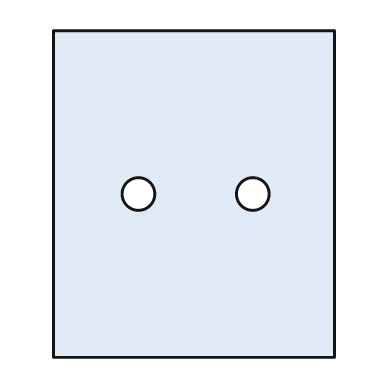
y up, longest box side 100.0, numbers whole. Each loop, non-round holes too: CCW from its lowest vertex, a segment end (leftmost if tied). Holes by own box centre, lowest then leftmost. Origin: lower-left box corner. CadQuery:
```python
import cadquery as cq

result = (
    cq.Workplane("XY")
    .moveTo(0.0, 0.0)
    .lineTo(86.0, 0.0)
    .lineTo(86.0, 100.0)
    .lineTo(0.0, 100.0)
    .close()
    .moveTo(26.0, 50.0)
    .circle(5.0)
    .moveTo(61.0, 50.0)
    .circle(5.0)
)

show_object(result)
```